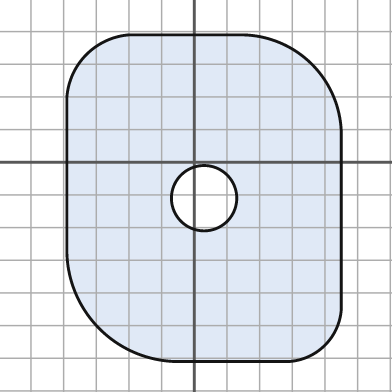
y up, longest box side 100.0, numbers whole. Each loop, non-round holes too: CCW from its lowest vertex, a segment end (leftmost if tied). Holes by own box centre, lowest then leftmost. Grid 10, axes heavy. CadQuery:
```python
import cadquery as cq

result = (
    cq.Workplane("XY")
    .moveTo(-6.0, -61.0)
    .lineTo(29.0, -61.0)
    .threePointArc((40.0, -56.0), (45.0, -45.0))
    .lineTo(45.0, 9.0)
    .threePointArc((36.0, 30.0), (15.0, 39.0))
    .lineTo(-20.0, 39.0)
    .threePointArc((-33.0, 33.0), (-39.0, 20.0))
    .lineTo(-39.0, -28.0)
    .threePointArc((-29.0, -51.0), (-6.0, -61.0))
    .close()
    .moveTo(3.0, -11.0)
    .circle(10.0)
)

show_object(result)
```